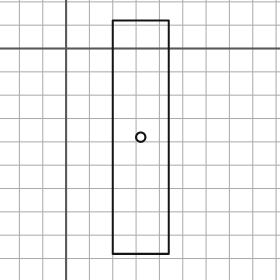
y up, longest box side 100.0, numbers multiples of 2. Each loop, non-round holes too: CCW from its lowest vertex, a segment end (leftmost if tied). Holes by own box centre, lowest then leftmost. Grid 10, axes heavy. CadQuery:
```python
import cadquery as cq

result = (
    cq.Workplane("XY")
    .moveTo(20.0, -88.0)
    .lineTo(44.0, -88.0)
    .lineTo(44.0, 12.0)
    .lineTo(20.0, 12.0)
    .close()
    .moveTo(32.0, -38.0)
    .circle(2.0)
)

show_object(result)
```